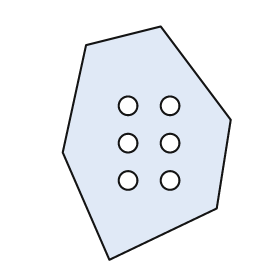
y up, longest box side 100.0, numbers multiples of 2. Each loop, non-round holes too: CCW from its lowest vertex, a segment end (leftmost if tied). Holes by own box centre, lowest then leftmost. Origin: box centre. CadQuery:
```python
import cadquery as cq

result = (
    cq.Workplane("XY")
    .moveTo(-16.0, -50.0)
    .lineTo(30.0, -28.0)
    .lineTo(36.0, 10.0)
    .lineTo(6.0, 50.0)
    .lineTo(-26.0, 42.0)
    .lineTo(-36.0, -4.0)
    .close()
    .moveTo(-8.0, -16.0)
    .circle(4.0)
    .moveTo(10.0, -16.0)
    .circle(4.0)
    .moveTo(-8.0, 0.0)
    .circle(4.0)
    .moveTo(10.0, 0.0)
    .circle(4.0)
    .moveTo(-8.0, 16.0)
    .circle(4.0)
    .moveTo(10.0, 16.0)
    .circle(4.0)
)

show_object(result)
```